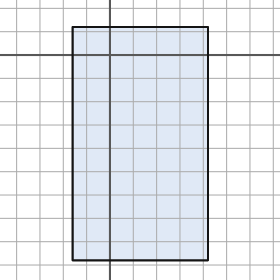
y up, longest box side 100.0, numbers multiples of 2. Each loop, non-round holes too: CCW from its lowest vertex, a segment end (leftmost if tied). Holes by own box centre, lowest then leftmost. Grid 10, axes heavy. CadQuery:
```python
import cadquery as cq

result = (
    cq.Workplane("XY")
    .moveTo(-16.0, -88.0)
    .lineTo(42.0, -88.0)
    .lineTo(42.0, 12.0)
    .lineTo(-16.0, 12.0)
    .close()
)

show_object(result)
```